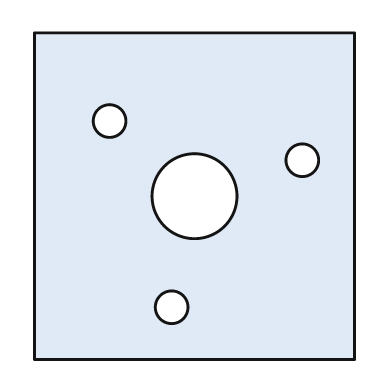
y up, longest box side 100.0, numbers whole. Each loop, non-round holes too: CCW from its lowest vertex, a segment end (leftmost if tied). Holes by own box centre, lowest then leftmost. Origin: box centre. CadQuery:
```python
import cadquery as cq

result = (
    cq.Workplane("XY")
    .moveTo(-49.0, -50.0)
    .lineTo(49.0, -50.0)
    .lineTo(49.0, 50.0)
    .lineTo(-49.0, 50.0)
    .close()
    .moveTo(-7.0, -34.0)
    .circle(5.0)
    .moveTo(0.0, 0.0)
    .circle(13.0)
    .moveTo(33.0, 11.0)
    .circle(5.0)
    .moveTo(-26.0, 23.0)
    .circle(5.0)
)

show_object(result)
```